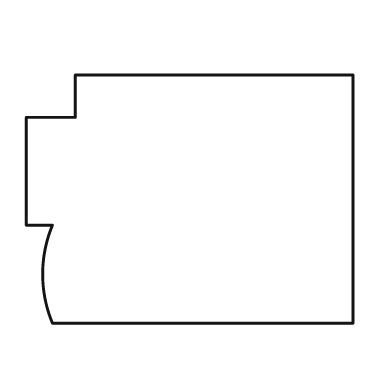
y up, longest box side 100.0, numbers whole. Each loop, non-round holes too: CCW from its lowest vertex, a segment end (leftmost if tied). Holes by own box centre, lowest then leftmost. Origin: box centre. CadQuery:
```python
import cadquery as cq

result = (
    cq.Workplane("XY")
    .moveTo(-42.0, -38.0)
    .lineTo(50.0, -38.0)
    .lineTo(50.0, 38.0)
    .lineTo(-35.0, 38.0)
    .lineTo(-35.0, 25.0)
    .lineTo(-50.0, 25.0)
    .lineTo(-50.0, -8.0)
    .lineTo(-42.0, -8.0)
    .threePointArc((-45.0, -23.0), (-42.0, -38.0))
    .close()
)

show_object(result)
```